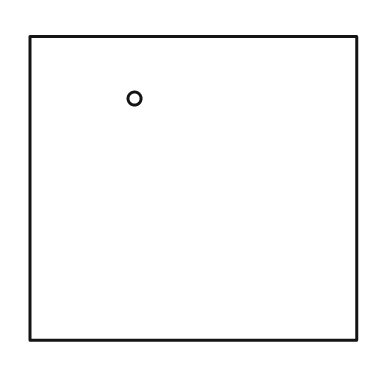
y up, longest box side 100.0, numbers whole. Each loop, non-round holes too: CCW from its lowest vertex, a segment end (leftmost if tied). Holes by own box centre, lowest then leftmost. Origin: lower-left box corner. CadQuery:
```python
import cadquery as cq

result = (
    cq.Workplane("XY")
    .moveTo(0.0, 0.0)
    .lineTo(100.0, 0.0)
    .lineTo(100.0, 93.0)
    .lineTo(0.0, 93.0)
    .close()
    .moveTo(32.0, 74.0)
    .circle(2.0)
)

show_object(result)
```